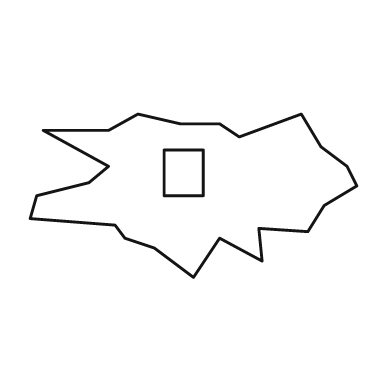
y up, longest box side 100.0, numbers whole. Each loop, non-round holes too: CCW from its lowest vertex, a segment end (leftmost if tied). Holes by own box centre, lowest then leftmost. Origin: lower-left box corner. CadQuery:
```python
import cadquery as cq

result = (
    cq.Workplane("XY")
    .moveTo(50.0, 0.0)
    .lineTo(58.0, 12.0)
    .lineTo(71.0, 5.0)
    .lineTo(70.0, 15.0)
    .lineTo(85.0, 14.0)
    .lineTo(90.0, 22.0)
    .lineTo(100.0, 28.0)
    .lineTo(97.0, 34.0)
    .lineTo(89.0, 40.0)
    .lineTo(83.0, 50.0)
    .lineTo(64.0, 43.0)
    .lineTo(58.0, 47.0)
    .lineTo(46.0, 47.0)
    .lineTo(33.0, 50.0)
    .lineTo(24.0, 45.0)
    .lineTo(4.0, 45.0)
    .lineTo(24.0, 34.0)
    .lineTo(18.0, 29.0)
    .lineTo(2.0, 25.0)
    .lineTo(0.0, 18.0)
    .lineTo(26.0, 16.0)
    .lineTo(29.0, 12.0)
    .lineTo(38.0, 9.0)
    .close()
    .moveTo(41.0, 25.0)
    .lineTo(53.0, 25.0)
    .lineTo(53.0, 39.0)
    .lineTo(41.0, 39.0)
    .close()
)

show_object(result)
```